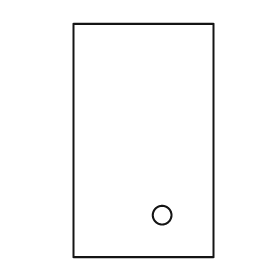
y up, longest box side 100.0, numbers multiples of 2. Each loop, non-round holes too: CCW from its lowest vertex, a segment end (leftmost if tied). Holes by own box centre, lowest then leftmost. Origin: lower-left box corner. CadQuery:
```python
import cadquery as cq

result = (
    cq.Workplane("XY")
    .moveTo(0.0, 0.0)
    .lineTo(60.0, 0.0)
    .lineTo(60.0, 100.0)
    .lineTo(0.0, 100.0)
    .close()
    .moveTo(38.0, 18.0)
    .circle(4.0)
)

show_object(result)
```